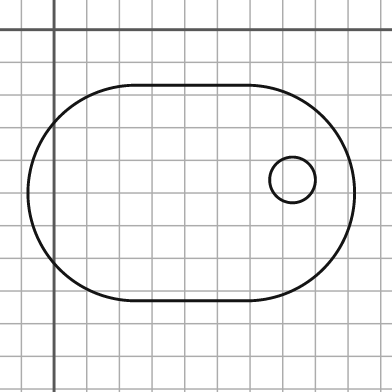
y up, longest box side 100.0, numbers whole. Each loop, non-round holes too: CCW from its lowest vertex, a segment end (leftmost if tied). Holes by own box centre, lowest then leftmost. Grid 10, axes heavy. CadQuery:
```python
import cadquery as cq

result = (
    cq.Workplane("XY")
    .moveTo(25.0, -83.0)
    .lineTo(59.0, -83.0)
    .threePointArc((92.0, -50.0), (59.0, -17.0))
    .lineTo(25.0, -17.0)
    .threePointArc((-8.0, -50.0), (25.0, -83.0))
    .close()
    .moveTo(73.0, -46.0)
    .circle(7.0)
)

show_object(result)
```